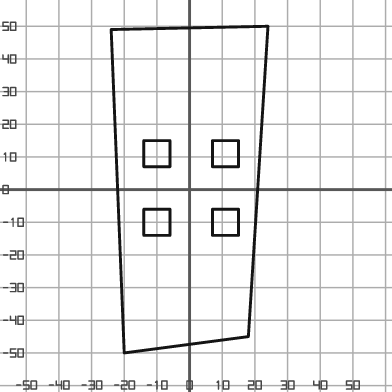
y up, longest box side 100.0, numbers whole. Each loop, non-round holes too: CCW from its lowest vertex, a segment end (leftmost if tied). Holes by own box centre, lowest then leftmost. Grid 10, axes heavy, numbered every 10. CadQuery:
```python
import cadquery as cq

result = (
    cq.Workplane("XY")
    .moveTo(-20.0, -50.0)
    .lineTo(18.0, -45.0)
    .lineTo(24.0, 50.0)
    .lineTo(-24.0, 49.0)
    .close()
    .moveTo(-14.0, -14.0)
    .lineTo(-6.0, -14.0)
    .lineTo(-6.0, -6.0)
    .lineTo(-14.0, -6.0)
    .close()
    .moveTo(7.0, -14.0)
    .lineTo(15.0, -14.0)
    .lineTo(15.0, -6.0)
    .lineTo(7.0, -6.0)
    .close()
    .moveTo(-14.0, 7.0)
    .lineTo(-6.0, 7.0)
    .lineTo(-6.0, 15.0)
    .lineTo(-14.0, 15.0)
    .close()
    .moveTo(7.0, 7.0)
    .lineTo(15.0, 7.0)
    .lineTo(15.0, 15.0)
    .lineTo(7.0, 15.0)
    .close()
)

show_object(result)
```